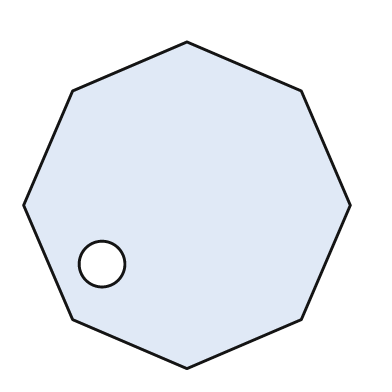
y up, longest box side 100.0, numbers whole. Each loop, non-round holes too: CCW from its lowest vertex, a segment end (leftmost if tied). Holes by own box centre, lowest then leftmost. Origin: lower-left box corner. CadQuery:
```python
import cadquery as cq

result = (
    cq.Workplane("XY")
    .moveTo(50.0, 0.0)
    .lineTo(85.0, 15.0)
    .lineTo(100.0, 50.0)
    .lineTo(85.0, 85.0)
    .lineTo(50.0, 100.0)
    .lineTo(15.0, 85.0)
    .lineTo(0.0, 50.0)
    .lineTo(15.0, 15.0)
    .close()
    .moveTo(24.0, 32.0)
    .circle(7.0)
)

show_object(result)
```